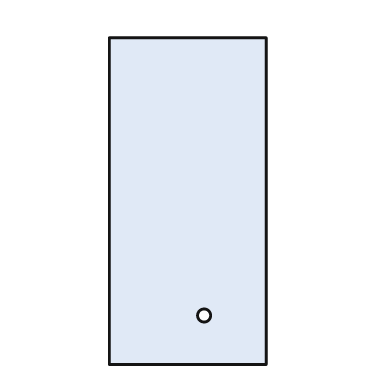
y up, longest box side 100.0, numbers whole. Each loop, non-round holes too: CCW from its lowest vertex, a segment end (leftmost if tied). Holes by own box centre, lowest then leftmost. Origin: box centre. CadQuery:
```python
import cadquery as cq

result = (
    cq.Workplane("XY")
    .moveTo(-24.0, -50.0)
    .lineTo(24.0, -50.0)
    .lineTo(24.0, 50.0)
    .lineTo(-24.0, 50.0)
    .close()
    .moveTo(5.0, -35.0)
    .circle(2.0)
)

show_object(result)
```